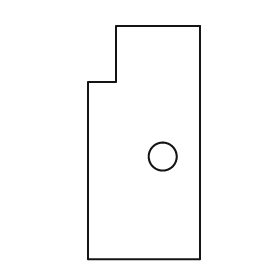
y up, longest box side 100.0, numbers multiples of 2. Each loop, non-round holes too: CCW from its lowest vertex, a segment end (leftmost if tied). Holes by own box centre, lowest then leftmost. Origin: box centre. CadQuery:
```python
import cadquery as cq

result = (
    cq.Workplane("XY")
    .moveTo(-24.0, -50.0)
    .lineTo(24.0, -50.0)
    .lineTo(24.0, 50.0)
    .lineTo(-12.0, 50.0)
    .lineTo(-12.0, 26.0)
    .lineTo(-24.0, 26.0)
    .close()
    .moveTo(8.0, -6.0)
    .circle(6.0)
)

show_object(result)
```